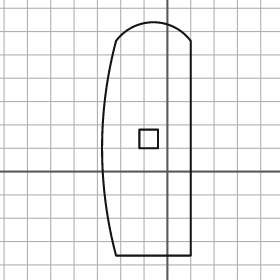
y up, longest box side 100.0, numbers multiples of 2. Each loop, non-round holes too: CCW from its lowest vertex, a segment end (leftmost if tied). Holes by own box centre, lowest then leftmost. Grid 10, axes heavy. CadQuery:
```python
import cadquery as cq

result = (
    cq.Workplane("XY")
    .moveTo(-22.0, -36.0)
    .lineTo(10.0, -36.0)
    .lineTo(10.0, 56.0)
    .threePointArc((-6.0, 64.0), (-22.0, 56.0))
    .threePointArc((-28.0, 10.0), (-22.0, -36.0))
    .close()
    .moveTo(-12.0, 10.0)
    .lineTo(-4.0, 10.0)
    .lineTo(-4.0, 18.0)
    .lineTo(-12.0, 18.0)
    .close()
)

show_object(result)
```